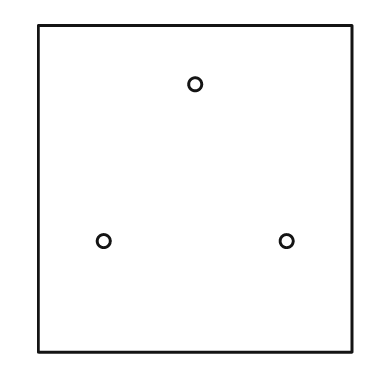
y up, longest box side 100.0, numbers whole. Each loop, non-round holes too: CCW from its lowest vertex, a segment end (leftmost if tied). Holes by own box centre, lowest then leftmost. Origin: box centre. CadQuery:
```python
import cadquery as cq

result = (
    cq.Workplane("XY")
    .moveTo(-48.0, -50.0)
    .lineTo(48.0, -50.0)
    .lineTo(48.0, 50.0)
    .lineTo(-48.0, 50.0)
    .close()
    .moveTo(-28.0, -16.0)
    .circle(2.0)
    .moveTo(28.0, -16.0)
    .circle(2.0)
    .moveTo(0.0, 32.0)
    .circle(2.0)
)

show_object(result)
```